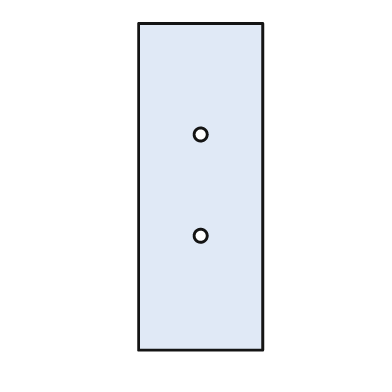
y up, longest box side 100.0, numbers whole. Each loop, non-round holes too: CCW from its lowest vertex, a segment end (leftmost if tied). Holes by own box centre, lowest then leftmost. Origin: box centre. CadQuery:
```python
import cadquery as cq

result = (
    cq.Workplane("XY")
    .moveTo(-19.0, -50.0)
    .lineTo(19.0, -50.0)
    .lineTo(19.0, 50.0)
    .lineTo(-19.0, 50.0)
    .close()
    .moveTo(0.0, -15.0)
    .circle(2.0)
    .moveTo(0.0, 16.0)
    .circle(2.0)
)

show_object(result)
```